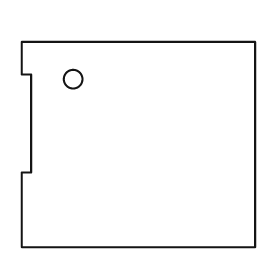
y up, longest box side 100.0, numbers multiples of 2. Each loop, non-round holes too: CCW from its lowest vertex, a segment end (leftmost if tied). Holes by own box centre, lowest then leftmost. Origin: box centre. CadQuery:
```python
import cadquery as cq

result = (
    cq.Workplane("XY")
    .moveTo(-50.0, -44.0)
    .lineTo(50.0, -44.0)
    .lineTo(50.0, 44.0)
    .lineTo(-50.0, 44.0)
    .lineTo(-50.0, 30.0)
    .lineTo(-46.0, 30.0)
    .lineTo(-46.0, -12.0)
    .lineTo(-50.0, -12.0)
    .close()
    .moveTo(-28.0, 28.0)
    .circle(4.0)
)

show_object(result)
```